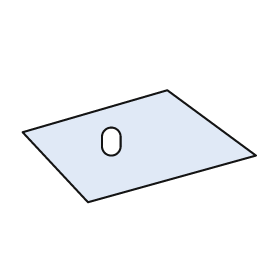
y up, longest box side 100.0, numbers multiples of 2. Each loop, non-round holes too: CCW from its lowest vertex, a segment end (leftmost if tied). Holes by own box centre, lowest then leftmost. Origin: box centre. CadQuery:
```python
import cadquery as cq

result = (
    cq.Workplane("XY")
    .moveTo(-22.0, -24.0)
    .lineTo(50.0, -4.0)
    .lineTo(12.0, 24.0)
    .lineTo(-50.0, 6.0)
    .close()
    .moveTo(-16.0, 0.0)
    .threePointArc((-12.0, -4.0), (-8.0, 0.0))
    .lineTo(-8.0, 4.0)
    .threePointArc((-12.0, 8.0), (-16.0, 4.0))
    .close()
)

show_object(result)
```